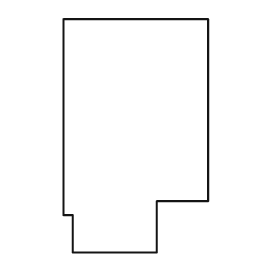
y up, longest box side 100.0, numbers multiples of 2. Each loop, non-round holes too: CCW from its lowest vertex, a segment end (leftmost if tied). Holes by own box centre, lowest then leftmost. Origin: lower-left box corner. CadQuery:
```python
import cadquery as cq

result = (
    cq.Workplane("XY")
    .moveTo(4.0, 0.0)
    .lineTo(40.0, 0.0)
    .lineTo(40.0, 22.0)
    .lineTo(62.0, 22.0)
    .lineTo(62.0, 100.0)
    .lineTo(0.0, 100.0)
    .lineTo(0.0, 16.0)
    .lineTo(4.0, 16.0)
    .close()
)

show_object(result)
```